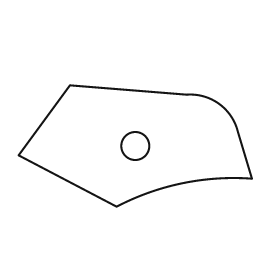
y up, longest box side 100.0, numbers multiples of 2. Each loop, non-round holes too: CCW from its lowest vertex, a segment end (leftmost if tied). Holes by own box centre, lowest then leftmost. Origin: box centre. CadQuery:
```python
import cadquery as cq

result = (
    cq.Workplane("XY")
    .moveTo(-8.0, -26.0)
    .threePointArc((20.0, -16.0), (50.0, -14.0))
    .lineTo(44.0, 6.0)
    .threePointArc((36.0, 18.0), (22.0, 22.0))
    .lineTo(-28.0, 26.0)
    .lineTo(-50.0, -4.0)
    .close()
    .moveTo(0.0, 0.0)
    .circle(6.0)
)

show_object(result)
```